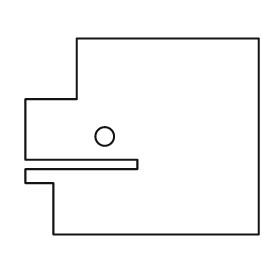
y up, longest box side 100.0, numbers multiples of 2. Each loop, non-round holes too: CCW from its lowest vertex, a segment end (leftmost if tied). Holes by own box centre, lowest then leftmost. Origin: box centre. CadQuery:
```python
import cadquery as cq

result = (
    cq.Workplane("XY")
    .moveTo(-38.0, -42.0)
    .lineTo(50.0, -42.0)
    .lineTo(50.0, 42.0)
    .lineTo(-28.0, 42.0)
    .lineTo(-28.0, 16.0)
    .lineTo(-50.0, 16.0)
    .lineTo(-50.0, -10.0)
    .lineTo(-2.0, -10.0)
    .lineTo(-2.0, -14.0)
    .lineTo(-50.0, -14.0)
    .lineTo(-50.0, -20.0)
    .lineTo(-38.0, -20.0)
    .close()
    .moveTo(-16.0, 0.0)
    .circle(4.0)
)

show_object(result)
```